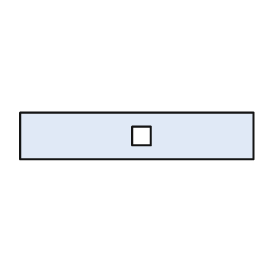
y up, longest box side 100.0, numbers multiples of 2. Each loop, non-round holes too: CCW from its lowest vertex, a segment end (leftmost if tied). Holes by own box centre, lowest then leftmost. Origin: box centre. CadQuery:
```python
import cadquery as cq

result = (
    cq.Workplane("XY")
    .moveTo(-50.0, -10.0)
    .lineTo(50.0, -10.0)
    .lineTo(50.0, 10.0)
    .lineTo(-50.0, 10.0)
    .close()
    .moveTo(-2.0, -4.0)
    .lineTo(6.0, -4.0)
    .lineTo(6.0, 4.0)
    .lineTo(-2.0, 4.0)
    .close()
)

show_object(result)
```